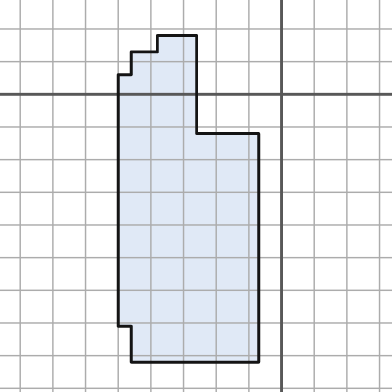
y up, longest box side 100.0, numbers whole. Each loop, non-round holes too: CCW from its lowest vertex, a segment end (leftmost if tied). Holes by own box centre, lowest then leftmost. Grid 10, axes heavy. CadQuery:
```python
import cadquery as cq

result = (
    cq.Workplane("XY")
    .moveTo(-46.0, -82.0)
    .lineTo(-7.0, -82.0)
    .lineTo(-7.0, -12.0)
    .lineTo(-26.0, -12.0)
    .lineTo(-26.0, 18.0)
    .lineTo(-38.0, 18.0)
    .lineTo(-38.0, 13.0)
    .lineTo(-46.0, 13.0)
    .lineTo(-46.0, 6.0)
    .lineTo(-50.0, 6.0)
    .lineTo(-50.0, -71.0)
    .lineTo(-46.0, -71.0)
    .close()
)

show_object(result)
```